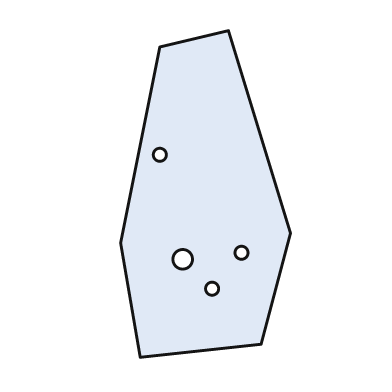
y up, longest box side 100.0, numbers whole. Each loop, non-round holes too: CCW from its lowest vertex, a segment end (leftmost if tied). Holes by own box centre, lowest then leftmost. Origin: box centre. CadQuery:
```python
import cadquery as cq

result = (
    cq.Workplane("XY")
    .moveTo(-20.0, -50.0)
    .lineTo(17.0, -46.0)
    .lineTo(26.0, -12.0)
    .lineTo(7.0, 50.0)
    .lineTo(-14.0, 45.0)
    .lineTo(-26.0, -15.0)
    .close()
    .moveTo(2.0, -29.0)
    .circle(2.0)
    .moveTo(-7.0, -20.0)
    .circle(3.0)
    .moveTo(11.0, -18.0)
    .circle(2.0)
    .moveTo(-14.0, 12.0)
    .circle(2.0)
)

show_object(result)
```